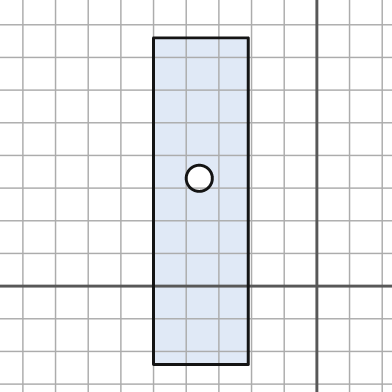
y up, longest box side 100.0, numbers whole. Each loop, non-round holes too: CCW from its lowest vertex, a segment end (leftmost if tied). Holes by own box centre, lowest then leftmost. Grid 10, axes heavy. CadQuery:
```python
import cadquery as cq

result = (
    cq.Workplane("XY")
    .moveTo(-50.0, -24.0)
    .lineTo(-21.0, -24.0)
    .lineTo(-21.0, 76.0)
    .lineTo(-50.0, 76.0)
    .close()
    .moveTo(-36.0, 33.0)
    .circle(4.0)
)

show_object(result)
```